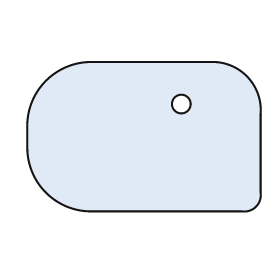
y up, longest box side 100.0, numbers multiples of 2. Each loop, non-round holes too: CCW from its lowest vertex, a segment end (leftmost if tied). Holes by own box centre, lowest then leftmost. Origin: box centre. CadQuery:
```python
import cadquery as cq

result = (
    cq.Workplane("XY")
    .moveTo(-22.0, -32.0)
    .lineTo(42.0, -32.0)
    .threePointArc((48.0, -30.0), (50.0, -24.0))
    .lineTo(50.0, 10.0)
    .threePointArc((44.0, 26.0), (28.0, 32.0))
    .lineTo(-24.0, 32.0)
    .threePointArc((-42.0, 24.0), (-50.0, 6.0))
    .lineTo(-50.0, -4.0)
    .threePointArc((-42.0, -24.0), (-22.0, -32.0))
    .close()
    .moveTo(16.0, 14.0)
    .circle(4.0)
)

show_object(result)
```